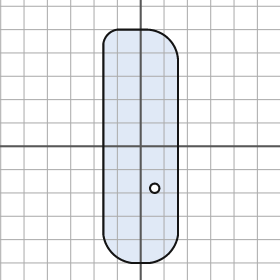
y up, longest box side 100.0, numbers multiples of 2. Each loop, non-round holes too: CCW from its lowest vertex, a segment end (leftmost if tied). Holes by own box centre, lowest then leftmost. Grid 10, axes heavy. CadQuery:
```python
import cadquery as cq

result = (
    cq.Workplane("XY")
    .moveTo(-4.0, -50.0)
    .lineTo(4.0, -50.0)
    .threePointArc((12.0, -46.0), (16.0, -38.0))
    .lineTo(16.0, 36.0)
    .threePointArc((12.0, 46.0), (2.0, 50.0))
    .lineTo(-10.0, 50.0)
    .threePointArc((-14.0, 48.0), (-16.0, 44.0))
    .lineTo(-16.0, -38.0)
    .threePointArc((-12.0, -46.0), (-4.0, -50.0))
    .close()
    .moveTo(6.0, -18.0)
    .circle(2.0)
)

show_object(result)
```